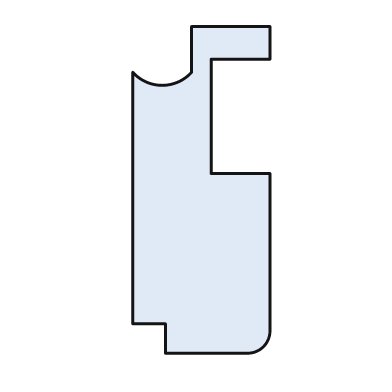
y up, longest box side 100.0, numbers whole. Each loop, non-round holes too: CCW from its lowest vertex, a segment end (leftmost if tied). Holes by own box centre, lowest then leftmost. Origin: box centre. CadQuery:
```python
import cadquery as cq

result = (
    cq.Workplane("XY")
    .moveTo(-11.0, -50.0)
    .lineTo(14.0, -50.0)
    .threePointArc((19.0, -48.0), (21.0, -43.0))
    .lineTo(21.0, 5.0)
    .lineTo(3.0, 5.0)
    .lineTo(3.0, 40.0)
    .lineTo(21.0, 40.0)
    .lineTo(21.0, 50.0)
    .lineTo(-3.0, 50.0)
    .lineTo(-3.0, 36.0)
    .threePointArc((-12.0, 32.0), (-21.0, 36.0))
    .lineTo(-21.0, -41.0)
    .lineTo(-11.0, -41.0)
    .close()
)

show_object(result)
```